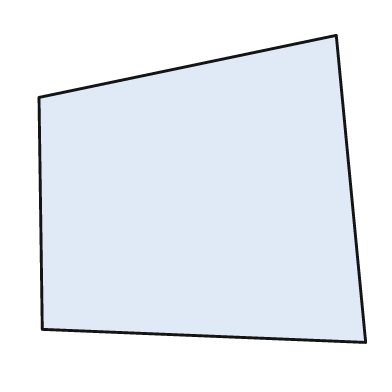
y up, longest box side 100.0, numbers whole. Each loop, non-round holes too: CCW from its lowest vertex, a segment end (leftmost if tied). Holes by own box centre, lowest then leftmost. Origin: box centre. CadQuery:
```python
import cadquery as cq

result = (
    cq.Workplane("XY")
    .moveTo(50.0, -47.0)
    .lineTo(41.0, 47.0)
    .lineTo(-50.0, 28.0)
    .lineTo(-49.0, -43.0)
    .close()
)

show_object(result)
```